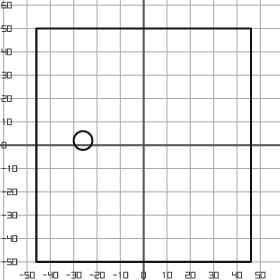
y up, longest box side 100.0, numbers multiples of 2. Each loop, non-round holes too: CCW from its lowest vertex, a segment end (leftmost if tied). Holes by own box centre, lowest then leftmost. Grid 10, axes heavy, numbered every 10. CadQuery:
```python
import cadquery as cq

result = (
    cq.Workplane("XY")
    .moveTo(-46.0, -50.0)
    .lineTo(46.0, -50.0)
    .lineTo(46.0, 50.0)
    .lineTo(-46.0, 50.0)
    .close()
    .moveTo(-26.0, 2.0)
    .circle(4.0)
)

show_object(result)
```